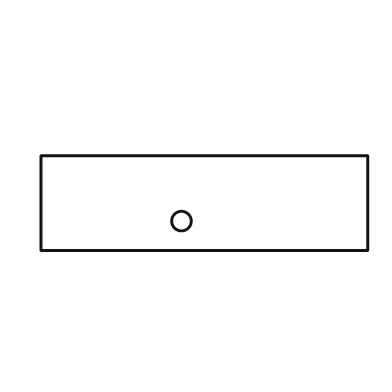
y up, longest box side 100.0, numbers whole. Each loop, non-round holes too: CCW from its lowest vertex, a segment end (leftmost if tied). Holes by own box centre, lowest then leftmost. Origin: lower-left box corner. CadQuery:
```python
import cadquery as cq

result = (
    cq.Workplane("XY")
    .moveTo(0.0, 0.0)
    .lineTo(100.0, 0.0)
    .lineTo(100.0, 29.0)
    .lineTo(0.0, 29.0)
    .close()
    .moveTo(43.0, 9.0)
    .circle(3.0)
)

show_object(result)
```